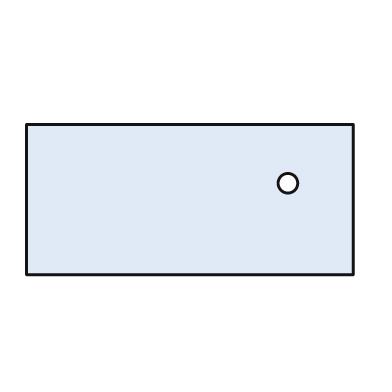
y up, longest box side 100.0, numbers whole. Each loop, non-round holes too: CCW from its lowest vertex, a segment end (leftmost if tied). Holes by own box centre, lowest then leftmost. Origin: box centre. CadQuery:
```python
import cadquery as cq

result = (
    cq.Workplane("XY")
    .moveTo(-50.0, -23.0)
    .lineTo(50.0, -23.0)
    .lineTo(50.0, 23.0)
    .lineTo(-50.0, 23.0)
    .close()
    .moveTo(30.0, 5.0)
    .circle(3.0)
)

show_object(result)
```